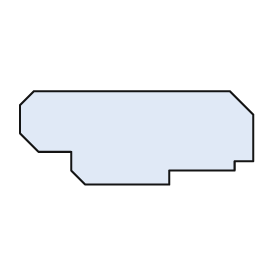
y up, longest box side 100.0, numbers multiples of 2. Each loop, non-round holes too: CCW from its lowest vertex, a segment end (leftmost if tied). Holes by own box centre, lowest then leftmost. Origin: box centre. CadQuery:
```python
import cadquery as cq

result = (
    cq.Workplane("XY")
    .moveTo(-22.0, -20.0)
    .lineTo(14.0, -20.0)
    .lineTo(14.0, -14.0)
    .lineTo(42.0, -14.0)
    .lineTo(42.0, -10.0)
    .lineTo(50.0, -10.0)
    .lineTo(50.0, 10.0)
    .lineTo(40.0, 20.0)
    .lineTo(-44.0, 20.0)
    .lineTo(-50.0, 14.0)
    .lineTo(-50.0, 2.0)
    .lineTo(-42.0, -6.0)
    .lineTo(-28.0, -6.0)
    .lineTo(-28.0, -14.0)
    .close()
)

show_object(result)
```